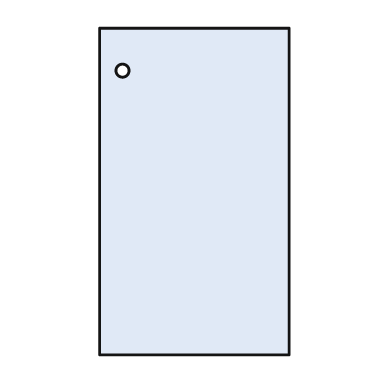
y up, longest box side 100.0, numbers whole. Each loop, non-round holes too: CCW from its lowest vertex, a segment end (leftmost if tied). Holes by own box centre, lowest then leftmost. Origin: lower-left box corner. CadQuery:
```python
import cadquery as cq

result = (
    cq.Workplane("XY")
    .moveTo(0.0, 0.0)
    .lineTo(58.0, 0.0)
    .lineTo(58.0, 100.0)
    .lineTo(0.0, 100.0)
    .close()
    .moveTo(7.0, 87.0)
    .circle(2.0)
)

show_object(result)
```